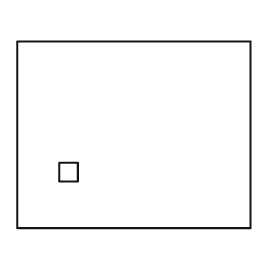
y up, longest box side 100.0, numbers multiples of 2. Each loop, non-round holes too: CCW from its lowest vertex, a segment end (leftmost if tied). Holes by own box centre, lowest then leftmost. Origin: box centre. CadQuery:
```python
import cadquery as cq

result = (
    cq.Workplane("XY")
    .moveTo(-50.0, -40.0)
    .lineTo(50.0, -40.0)
    .lineTo(50.0, 40.0)
    .lineTo(-50.0, 40.0)
    .close()
    .moveTo(-32.0, -20.0)
    .lineTo(-24.0, -20.0)
    .lineTo(-24.0, -12.0)
    .lineTo(-32.0, -12.0)
    .close()
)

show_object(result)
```